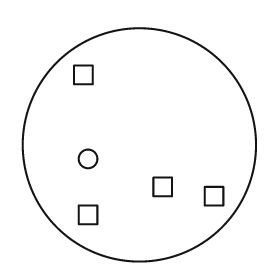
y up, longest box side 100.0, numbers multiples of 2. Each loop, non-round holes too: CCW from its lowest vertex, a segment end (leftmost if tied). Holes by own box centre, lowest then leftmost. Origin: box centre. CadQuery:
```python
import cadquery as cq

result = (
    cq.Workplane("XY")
    .moveTo(0.0, 0.0)
    .circle(50.0)
    .moveTo(-26.0, -34.0)
    .lineTo(-18.0, -34.0)
    .lineTo(-18.0, -26.0)
    .lineTo(-26.0, -26.0)
    .close()
    .moveTo(28.0, -26.0)
    .lineTo(36.0, -26.0)
    .lineTo(36.0, -18.0)
    .lineTo(28.0, -18.0)
    .close()
    .moveTo(6.0, -22.0)
    .lineTo(14.0, -22.0)
    .lineTo(14.0, -14.0)
    .lineTo(6.0, -14.0)
    .close()
    .moveTo(-22.0, -6.0)
    .circle(4.0)
    .moveTo(-28.0, 26.0)
    .lineTo(-20.0, 26.0)
    .lineTo(-20.0, 34.0)
    .lineTo(-28.0, 34.0)
    .close()
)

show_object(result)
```